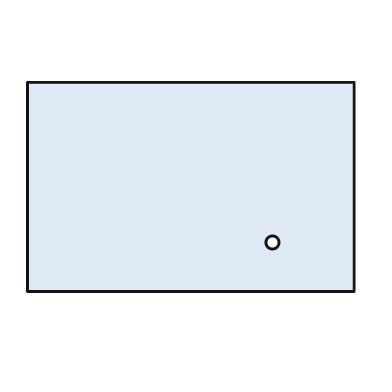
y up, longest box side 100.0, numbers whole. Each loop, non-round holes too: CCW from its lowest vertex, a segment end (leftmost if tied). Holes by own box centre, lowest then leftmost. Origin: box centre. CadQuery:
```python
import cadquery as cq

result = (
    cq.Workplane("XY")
    .moveTo(-50.0, -32.0)
    .lineTo(50.0, -32.0)
    .lineTo(50.0, 32.0)
    .lineTo(-50.0, 32.0)
    .close()
    .moveTo(25.0, -17.0)
    .circle(2.0)
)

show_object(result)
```